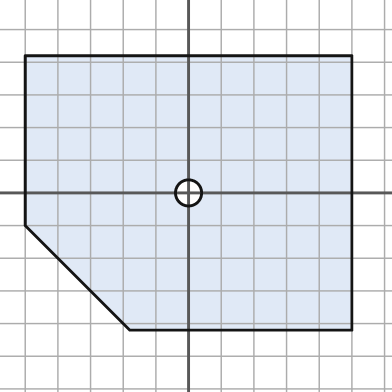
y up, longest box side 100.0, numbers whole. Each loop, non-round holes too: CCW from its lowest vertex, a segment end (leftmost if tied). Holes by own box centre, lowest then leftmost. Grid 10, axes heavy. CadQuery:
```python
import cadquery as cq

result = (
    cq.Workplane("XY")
    .moveTo(-18.0, -42.0)
    .lineTo(50.0, -42.0)
    .lineTo(50.0, 42.0)
    .lineTo(-50.0, 42.0)
    .lineTo(-50.0, -10.0)
    .close()
    .moveTo(0.0, 0.0)
    .circle(4.0)
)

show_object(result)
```